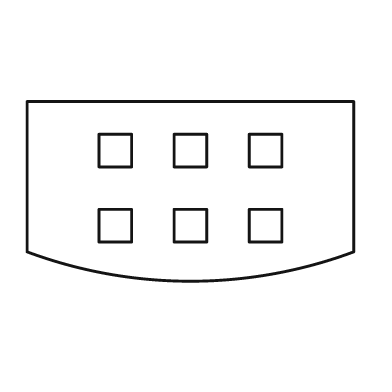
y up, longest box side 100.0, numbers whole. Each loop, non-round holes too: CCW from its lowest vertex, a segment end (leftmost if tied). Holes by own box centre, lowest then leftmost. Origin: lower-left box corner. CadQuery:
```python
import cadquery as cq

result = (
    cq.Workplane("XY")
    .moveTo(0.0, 9.0)
    .threePointArc((50.0, 0.0), (100.0, 9.0))
    .lineTo(100.0, 55.0)
    .lineTo(0.0, 55.0)
    .close()
    .moveTo(22.0, 12.0)
    .lineTo(32.0, 12.0)
    .lineTo(32.0, 22.0)
    .lineTo(22.0, 22.0)
    .close()
    .moveTo(45.0, 12.0)
    .lineTo(55.0, 12.0)
    .lineTo(55.0, 22.0)
    .lineTo(45.0, 22.0)
    .close()
    .moveTo(68.0, 12.0)
    .lineTo(78.0, 12.0)
    .lineTo(78.0, 22.0)
    .lineTo(68.0, 22.0)
    .close()
    .moveTo(22.0, 35.0)
    .lineTo(32.0, 35.0)
    .lineTo(32.0, 45.0)
    .lineTo(22.0, 45.0)
    .close()
    .moveTo(45.0, 35.0)
    .lineTo(55.0, 35.0)
    .lineTo(55.0, 45.0)
    .lineTo(45.0, 45.0)
    .close()
    .moveTo(68.0, 35.0)
    .lineTo(78.0, 35.0)
    .lineTo(78.0, 45.0)
    .lineTo(68.0, 45.0)
    .close()
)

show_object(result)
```